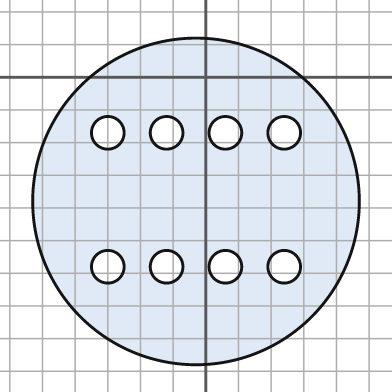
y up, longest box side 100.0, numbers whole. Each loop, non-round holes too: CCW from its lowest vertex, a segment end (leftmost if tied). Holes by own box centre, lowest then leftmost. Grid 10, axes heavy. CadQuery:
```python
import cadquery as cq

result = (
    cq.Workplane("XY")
    .moveTo(-3.0, -38.0)
    .circle(50.0)
    .moveTo(-30.0, -58.0)
    .circle(5.0)
    .moveTo(-12.0, -58.0)
    .circle(5.0)
    .moveTo(6.0, -58.0)
    .circle(5.0)
    .moveTo(24.0, -58.0)
    .circle(5.0)
    .moveTo(-30.0, -17.0)
    .circle(5.0)
    .moveTo(-12.0, -17.0)
    .circle(5.0)
    .moveTo(6.0, -17.0)
    .circle(5.0)
    .moveTo(24.0, -17.0)
    .circle(5.0)
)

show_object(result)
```